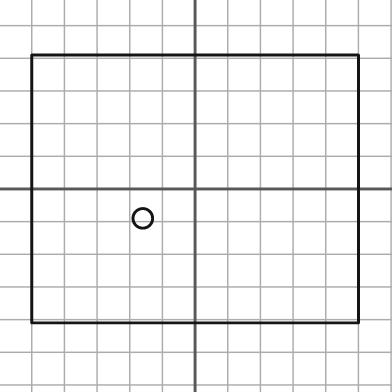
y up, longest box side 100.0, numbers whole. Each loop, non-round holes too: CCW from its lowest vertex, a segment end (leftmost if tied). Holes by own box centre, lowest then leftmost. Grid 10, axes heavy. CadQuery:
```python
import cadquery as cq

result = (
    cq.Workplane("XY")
    .moveTo(-50.0, -41.0)
    .lineTo(50.0, -41.0)
    .lineTo(50.0, 41.0)
    .lineTo(-50.0, 41.0)
    .close()
    .moveTo(-16.0, -9.0)
    .circle(3.0)
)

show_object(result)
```